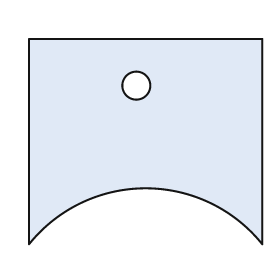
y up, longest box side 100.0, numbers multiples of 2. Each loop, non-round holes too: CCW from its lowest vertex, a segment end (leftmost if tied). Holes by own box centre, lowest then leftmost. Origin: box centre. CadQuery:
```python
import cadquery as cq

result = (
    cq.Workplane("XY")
    .moveTo(-50.0, -44.0)
    .threePointArc((0.0, -20.0), (50.0, -44.0))
    .lineTo(50.0, 44.0)
    .lineTo(-50.0, 44.0)
    .close()
    .moveTo(-4.0, 24.0)
    .circle(6.0)
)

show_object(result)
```